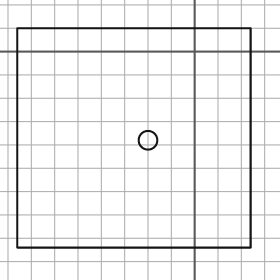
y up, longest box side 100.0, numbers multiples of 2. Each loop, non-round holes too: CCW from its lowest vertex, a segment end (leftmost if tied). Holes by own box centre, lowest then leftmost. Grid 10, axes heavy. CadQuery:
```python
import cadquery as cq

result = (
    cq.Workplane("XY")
    .moveTo(-76.0, -84.0)
    .lineTo(24.0, -84.0)
    .lineTo(24.0, 10.0)
    .lineTo(-76.0, 10.0)
    .close()
    .moveTo(-20.0, -38.0)
    .circle(4.0)
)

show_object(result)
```